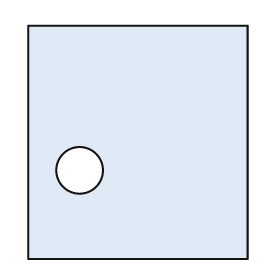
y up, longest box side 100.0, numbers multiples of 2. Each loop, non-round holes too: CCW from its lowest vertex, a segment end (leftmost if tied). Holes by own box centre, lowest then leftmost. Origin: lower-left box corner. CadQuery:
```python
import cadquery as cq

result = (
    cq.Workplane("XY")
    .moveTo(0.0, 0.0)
    .lineTo(94.0, 0.0)
    .lineTo(94.0, 100.0)
    .lineTo(0.0, 100.0)
    .close()
    .moveTo(22.0, 38.0)
    .circle(10.0)
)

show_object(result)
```